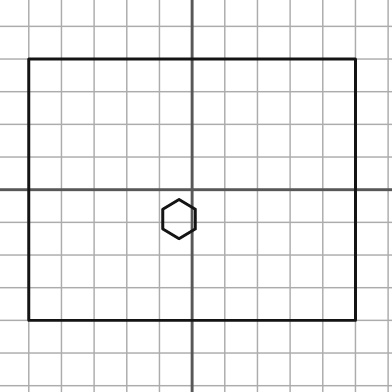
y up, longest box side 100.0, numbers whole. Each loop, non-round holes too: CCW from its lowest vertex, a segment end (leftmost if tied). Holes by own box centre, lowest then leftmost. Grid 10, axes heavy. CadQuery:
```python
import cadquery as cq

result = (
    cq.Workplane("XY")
    .moveTo(-50.0, -40.0)
    .lineTo(50.0, -40.0)
    .lineTo(50.0, 40.0)
    .lineTo(-50.0, 40.0)
    .close()
    .moveTo(-4.0, -15.0)
    .lineTo(1.0, -12.0)
    .lineTo(1.0, -6.0)
    .lineTo(-4.0, -3.0)
    .lineTo(-9.0, -6.0)
    .lineTo(-9.0, -12.0)
    .close()
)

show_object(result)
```